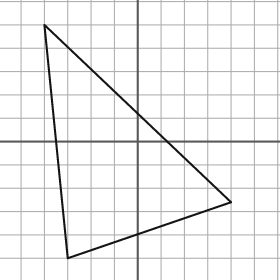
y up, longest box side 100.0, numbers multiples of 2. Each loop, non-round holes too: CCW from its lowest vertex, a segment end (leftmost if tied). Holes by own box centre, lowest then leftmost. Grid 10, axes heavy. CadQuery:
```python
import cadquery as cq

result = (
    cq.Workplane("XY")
    .moveTo(-30.0, -50.0)
    .lineTo(40.0, -26.0)
    .lineTo(-40.0, 50.0)
    .close()
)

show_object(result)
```